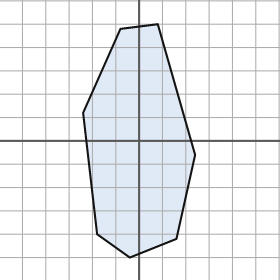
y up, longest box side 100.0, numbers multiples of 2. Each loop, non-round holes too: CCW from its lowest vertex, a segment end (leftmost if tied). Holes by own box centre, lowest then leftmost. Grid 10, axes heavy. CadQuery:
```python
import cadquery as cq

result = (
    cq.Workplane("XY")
    .moveTo(-4.0, -50.0)
    .lineTo(16.0, -42.0)
    .lineTo(24.0, -6.0)
    .lineTo(8.0, 50.0)
    .lineTo(-8.0, 48.0)
    .lineTo(-24.0, 12.0)
    .lineTo(-18.0, -40.0)
    .close()
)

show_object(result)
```